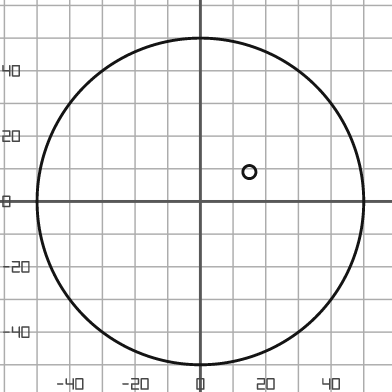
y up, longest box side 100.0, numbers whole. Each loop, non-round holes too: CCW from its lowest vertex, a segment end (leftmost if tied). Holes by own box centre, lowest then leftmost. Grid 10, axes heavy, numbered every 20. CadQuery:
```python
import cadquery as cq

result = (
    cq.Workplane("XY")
    .moveTo(0.0, 0.0)
    .circle(50.0)
    .moveTo(15.0, 9.0)
    .circle(2.0)
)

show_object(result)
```